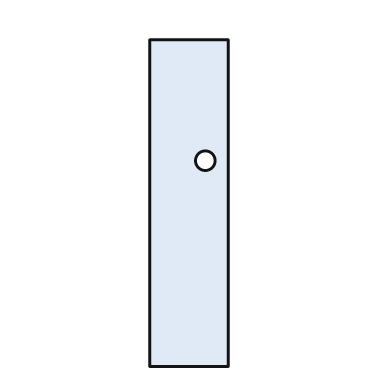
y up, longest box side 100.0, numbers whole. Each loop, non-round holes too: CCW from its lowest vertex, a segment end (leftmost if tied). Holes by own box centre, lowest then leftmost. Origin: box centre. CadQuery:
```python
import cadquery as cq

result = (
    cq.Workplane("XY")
    .moveTo(-12.0, -50.0)
    .lineTo(12.0, -50.0)
    .lineTo(12.0, 50.0)
    .lineTo(-12.0, 50.0)
    .close()
    .moveTo(5.0, 13.0)
    .circle(3.0)
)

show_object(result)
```